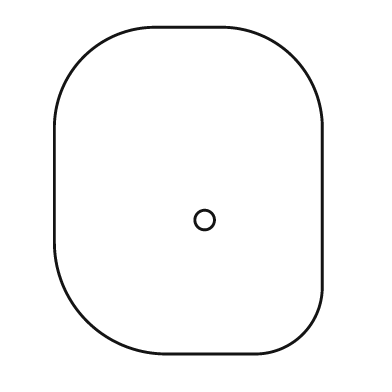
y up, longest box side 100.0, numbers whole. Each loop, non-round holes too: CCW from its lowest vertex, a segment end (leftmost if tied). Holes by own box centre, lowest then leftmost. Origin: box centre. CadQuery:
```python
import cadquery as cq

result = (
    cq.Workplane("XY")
    .moveTo(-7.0, -50.0)
    .lineTo(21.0, -50.0)
    .threePointArc((35.0, -44.0), (41.0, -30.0))
    .lineTo(41.0, 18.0)
    .threePointArc((32.0, 41.0), (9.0, 50.0))
    .lineTo(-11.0, 50.0)
    .threePointArc((-32.0, 41.0), (-41.0, 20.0))
    .lineTo(-41.0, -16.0)
    .threePointArc((-31.0, -40.0), (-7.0, -50.0))
    .close()
    .moveTo(5.0, -9.0)
    .circle(3.0)
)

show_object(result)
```